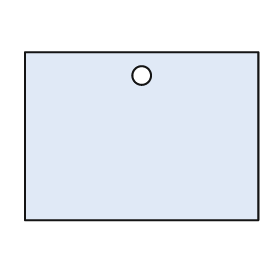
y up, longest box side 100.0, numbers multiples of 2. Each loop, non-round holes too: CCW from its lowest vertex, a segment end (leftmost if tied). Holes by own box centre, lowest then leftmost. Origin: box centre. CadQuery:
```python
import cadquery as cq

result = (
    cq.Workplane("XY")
    .moveTo(-50.0, -36.0)
    .lineTo(50.0, -36.0)
    .lineTo(50.0, 36.0)
    .lineTo(-50.0, 36.0)
    .close()
    .moveTo(0.0, 26.0)
    .circle(4.0)
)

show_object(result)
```